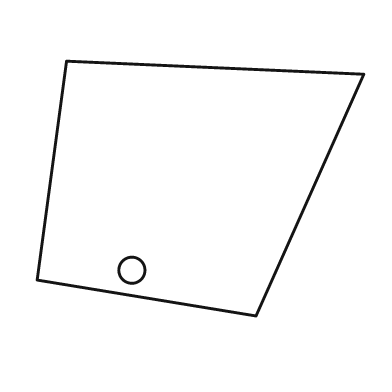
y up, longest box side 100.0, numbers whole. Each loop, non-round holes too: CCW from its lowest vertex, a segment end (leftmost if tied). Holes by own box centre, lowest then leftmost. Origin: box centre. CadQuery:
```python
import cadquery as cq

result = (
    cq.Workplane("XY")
    .moveTo(17.0, -39.0)
    .lineTo(50.0, 35.0)
    .lineTo(-41.0, 39.0)
    .lineTo(-50.0, -28.0)
    .close()
    .moveTo(-21.0, -25.0)
    .circle(4.0)
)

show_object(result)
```